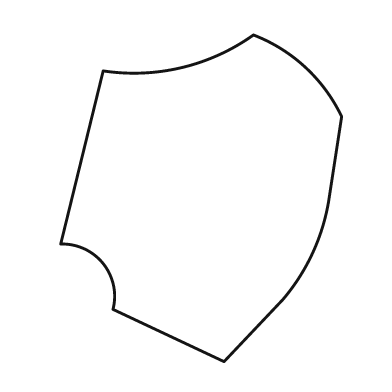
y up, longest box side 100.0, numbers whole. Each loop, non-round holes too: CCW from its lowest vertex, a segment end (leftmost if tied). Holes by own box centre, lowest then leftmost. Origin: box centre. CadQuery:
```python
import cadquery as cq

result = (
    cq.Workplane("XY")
    .moveTo(7.0, -50.0)
    .lineTo(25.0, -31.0)
    .threePointArc((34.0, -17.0), (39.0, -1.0))
    .lineTo(43.0, 25.0)
    .threePointArc((32.0, 40.0), (16.0, 50.0))
    .threePointArc((-6.0, 40.0), (-30.0, 39.0))
    .lineTo(-43.0, -14.0)
    .threePointArc((-30.0, -20.0), (-27.0, -34.0))
    .close()
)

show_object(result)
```